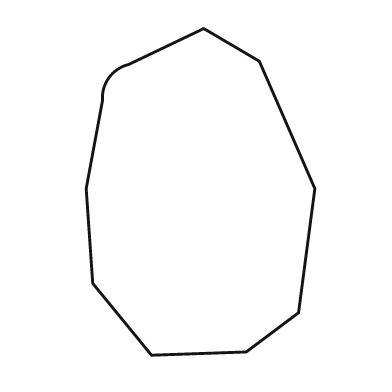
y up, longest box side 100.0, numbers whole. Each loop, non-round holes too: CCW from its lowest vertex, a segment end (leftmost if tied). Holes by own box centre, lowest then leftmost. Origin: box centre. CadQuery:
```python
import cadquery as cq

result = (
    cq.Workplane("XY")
    .moveTo(-15.0, -50.0)
    .lineTo(14.0, -49.0)
    .lineTo(30.0, -37.0)
    .lineTo(35.0, 1.0)
    .lineTo(18.0, 40.0)
    .lineTo(1.0, 50.0)
    .lineTo(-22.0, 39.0)
    .threePointArc((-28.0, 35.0), (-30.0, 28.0))
    .lineTo(-35.0, 1.0)
    .lineTo(-33.0, -28.0)
    .close()
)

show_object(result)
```